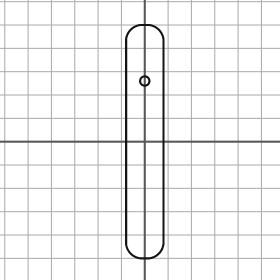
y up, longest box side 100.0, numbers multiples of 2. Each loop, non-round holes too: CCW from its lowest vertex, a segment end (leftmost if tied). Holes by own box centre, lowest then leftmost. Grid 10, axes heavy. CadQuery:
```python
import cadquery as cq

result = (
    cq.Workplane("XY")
    .moveTo(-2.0, -50.0)
    .lineTo(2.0, -50.0)
    .threePointArc((6.0, -48.0), (8.0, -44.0))
    .lineTo(8.0, 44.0)
    .threePointArc((6.0, 48.0), (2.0, 50.0))
    .lineTo(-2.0, 50.0)
    .threePointArc((-6.0, 48.0), (-8.0, 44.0))
    .lineTo(-8.0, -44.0)
    .threePointArc((-6.0, -48.0), (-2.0, -50.0))
    .close()
    .moveTo(0.0, 26.0)
    .circle(2.0)
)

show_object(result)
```